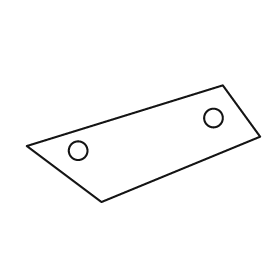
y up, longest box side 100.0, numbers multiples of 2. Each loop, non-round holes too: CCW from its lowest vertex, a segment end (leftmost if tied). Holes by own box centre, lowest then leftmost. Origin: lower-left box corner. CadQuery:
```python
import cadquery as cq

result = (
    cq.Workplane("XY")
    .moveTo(32.0, 0.0)
    .lineTo(100.0, 28.0)
    .lineTo(84.0, 50.0)
    .lineTo(0.0, 24.0)
    .close()
    .moveTo(22.0, 22.0)
    .circle(4.0)
    .moveTo(80.0, 36.0)
    .circle(4.0)
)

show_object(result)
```